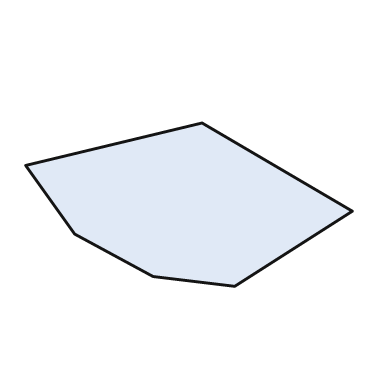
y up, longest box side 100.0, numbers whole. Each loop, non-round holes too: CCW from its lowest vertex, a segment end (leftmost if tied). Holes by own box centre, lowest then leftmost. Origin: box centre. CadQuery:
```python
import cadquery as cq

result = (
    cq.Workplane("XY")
    .moveTo(14.0, -25.0)
    .lineTo(50.0, -2.0)
    .lineTo(4.0, 25.0)
    .lineTo(-50.0, 12.0)
    .lineTo(-35.0, -9.0)
    .lineTo(-11.0, -22.0)
    .close()
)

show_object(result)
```